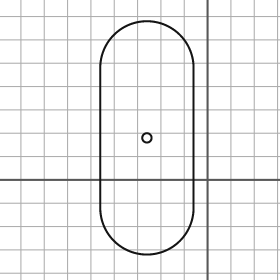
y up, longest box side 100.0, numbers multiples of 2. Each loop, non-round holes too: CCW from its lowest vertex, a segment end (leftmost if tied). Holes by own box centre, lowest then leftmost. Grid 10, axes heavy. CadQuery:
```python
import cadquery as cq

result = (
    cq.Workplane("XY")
    .moveTo(-46.0, -12.0)
    .threePointArc((-26.0, -32.0), (-6.0, -12.0))
    .lineTo(-6.0, 48.0)
    .threePointArc((-26.0, 68.0), (-46.0, 48.0))
    .close()
    .moveTo(-26.0, 18.0)
    .circle(2.0)
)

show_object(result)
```